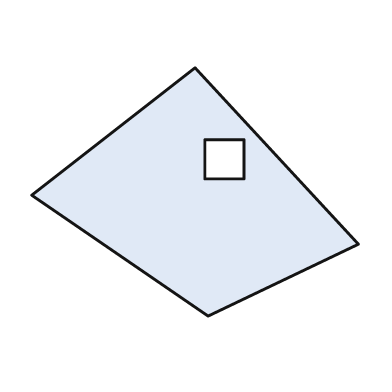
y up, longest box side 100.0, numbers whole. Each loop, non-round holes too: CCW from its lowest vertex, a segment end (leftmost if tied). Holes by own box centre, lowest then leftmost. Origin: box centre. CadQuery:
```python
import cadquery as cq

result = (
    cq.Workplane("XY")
    .moveTo(4.0, -38.0)
    .lineTo(50.0, -16.0)
    .lineTo(0.0, 38.0)
    .lineTo(-50.0, -1.0)
    .close()
    .moveTo(3.0, 4.0)
    .lineTo(15.0, 4.0)
    .lineTo(15.0, 16.0)
    .lineTo(3.0, 16.0)
    .close()
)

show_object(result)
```